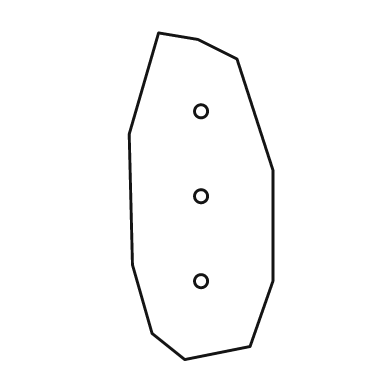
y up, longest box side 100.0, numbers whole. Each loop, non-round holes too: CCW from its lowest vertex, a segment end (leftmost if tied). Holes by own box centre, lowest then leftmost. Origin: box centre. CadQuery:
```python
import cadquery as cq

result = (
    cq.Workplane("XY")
    .moveTo(-5.0, -50.0)
    .lineTo(15.0, -46.0)
    .lineTo(22.0, -26.0)
    .lineTo(22.0, 8.0)
    .lineTo(11.0, 42.0)
    .lineTo(-1.0, 48.0)
    .lineTo(-13.0, 50.0)
    .lineTo(-22.0, 19.0)
    .lineTo(-21.0, -21.0)
    .lineTo(-15.0, -42.0)
    .close()
    .moveTo(0.0, -26.0)
    .circle(2.0)
    .moveTo(0.0, 0.0)
    .circle(2.0)
    .moveTo(0.0, 26.0)
    .circle(2.0)
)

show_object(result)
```